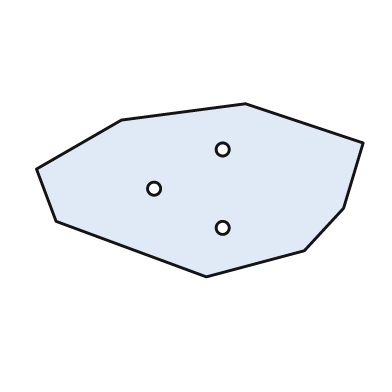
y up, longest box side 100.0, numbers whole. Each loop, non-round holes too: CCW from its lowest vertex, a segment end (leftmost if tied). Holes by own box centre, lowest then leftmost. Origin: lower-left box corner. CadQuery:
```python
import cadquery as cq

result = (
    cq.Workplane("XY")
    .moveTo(52.0, 0.0)
    .lineTo(82.0, 8.0)
    .lineTo(94.0, 21.0)
    .lineTo(100.0, 41.0)
    .lineTo(64.0, 53.0)
    .lineTo(26.0, 48.0)
    .lineTo(0.0, 33.0)
    .lineTo(6.0, 17.0)
    .close()
    .moveTo(57.0, 15.0)
    .circle(2.0)
    .moveTo(36.0, 27.0)
    .circle(2.0)
    .moveTo(57.0, 39.0)
    .circle(2.0)
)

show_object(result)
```